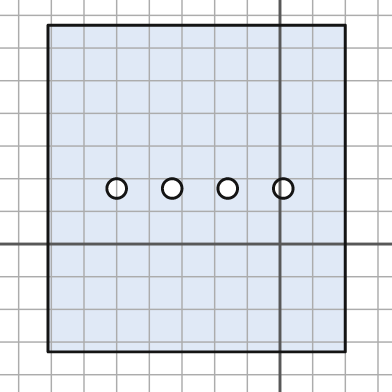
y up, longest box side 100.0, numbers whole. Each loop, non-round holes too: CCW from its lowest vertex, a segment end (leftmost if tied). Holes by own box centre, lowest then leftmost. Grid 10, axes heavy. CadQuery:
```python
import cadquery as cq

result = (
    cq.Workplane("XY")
    .moveTo(-71.0, -33.0)
    .lineTo(20.0, -33.0)
    .lineTo(20.0, 67.0)
    .lineTo(-71.0, 67.0)
    .close()
    .moveTo(-50.0, 17.0)
    .circle(3.0)
    .moveTo(-33.0, 17.0)
    .circle(3.0)
    .moveTo(-16.0, 17.0)
    .circle(3.0)
    .moveTo(1.0, 17.0)
    .circle(3.0)
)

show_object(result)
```